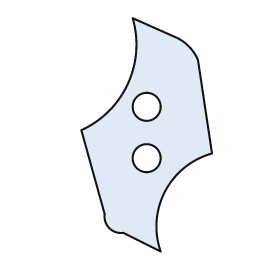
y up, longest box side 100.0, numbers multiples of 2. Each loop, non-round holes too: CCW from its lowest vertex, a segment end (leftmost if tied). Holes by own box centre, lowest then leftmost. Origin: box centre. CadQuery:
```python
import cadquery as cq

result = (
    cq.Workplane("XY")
    .moveTo(6.0, -50.0)
    .threePointArc((8.0, -24.0), (28.0, -8.0))
    .lineTo(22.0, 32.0)
    .threePointArc((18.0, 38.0), (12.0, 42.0))
    .lineTo(-6.0, 50.0)
    .threePointArc((-8.0, 22.0), (-28.0, 2.0))
    .lineTo(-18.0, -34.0)
    .threePointArc((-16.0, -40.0), (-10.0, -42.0))
    .close()
    .moveTo(0.0, -10.0)
    .circle(6.0)
    .moveTo(0.0, 12.0)
    .circle(6.0)
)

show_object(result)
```